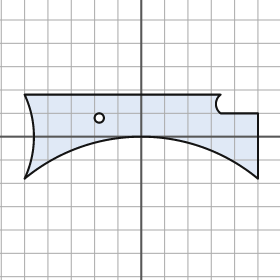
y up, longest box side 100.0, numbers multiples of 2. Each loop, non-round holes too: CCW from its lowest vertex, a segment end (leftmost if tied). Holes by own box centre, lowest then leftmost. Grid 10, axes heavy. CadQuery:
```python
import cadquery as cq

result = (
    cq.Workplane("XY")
    .moveTo(-50.0, -18.0)
    .threePointArc((0.0, 0.0), (50.0, -18.0))
    .lineTo(50.0, 10.0)
    .lineTo(34.0, 10.0)
    .threePointArc((32.0, 14.0), (34.0, 18.0))
    .lineTo(-50.0, 18.0)
    .threePointArc((-46.0, 0.0), (-50.0, -18.0))
    .close()
    .moveTo(-18.0, 8.0)
    .circle(2.0)
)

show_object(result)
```